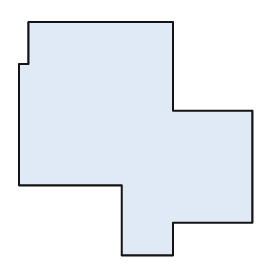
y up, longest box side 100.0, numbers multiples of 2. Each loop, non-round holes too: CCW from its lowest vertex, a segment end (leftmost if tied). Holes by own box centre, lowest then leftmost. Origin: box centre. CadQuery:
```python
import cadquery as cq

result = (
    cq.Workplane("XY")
    .moveTo(-6.0, -50.0)
    .lineTo(16.0, -50.0)
    .lineTo(16.0, -36.0)
    .lineTo(50.0, -36.0)
    .lineTo(50.0, 12.0)
    .lineTo(16.0, 12.0)
    .lineTo(16.0, 50.0)
    .lineTo(-46.0, 50.0)
    .lineTo(-46.0, 32.0)
    .lineTo(-50.0, 32.0)
    .lineTo(-50.0, -20.0)
    .lineTo(-6.0, -20.0)
    .close()
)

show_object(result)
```